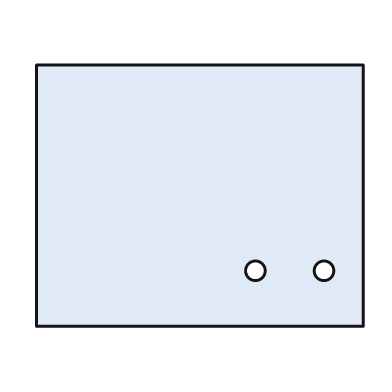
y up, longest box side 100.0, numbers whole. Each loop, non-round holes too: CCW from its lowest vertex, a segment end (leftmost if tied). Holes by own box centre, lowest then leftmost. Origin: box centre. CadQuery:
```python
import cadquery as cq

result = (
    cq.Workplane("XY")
    .moveTo(-50.0, -40.0)
    .lineTo(50.0, -40.0)
    .lineTo(50.0, 40.0)
    .lineTo(-50.0, 40.0)
    .close()
    .moveTo(17.0, -23.0)
    .circle(3.0)
    .moveTo(38.0, -23.0)
    .circle(3.0)
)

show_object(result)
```